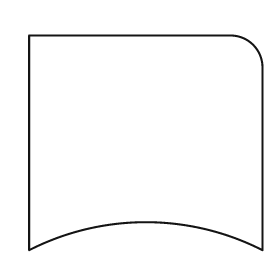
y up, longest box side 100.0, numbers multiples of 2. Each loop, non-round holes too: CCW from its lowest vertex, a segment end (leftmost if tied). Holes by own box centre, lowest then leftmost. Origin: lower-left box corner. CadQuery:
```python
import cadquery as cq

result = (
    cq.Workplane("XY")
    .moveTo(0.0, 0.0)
    .threePointArc((50.0, 12.0), (100.0, 0.0))
    .lineTo(100.0, 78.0)
    .threePointArc((96.0, 88.0), (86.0, 92.0))
    .lineTo(0.0, 92.0)
    .close()
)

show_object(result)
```